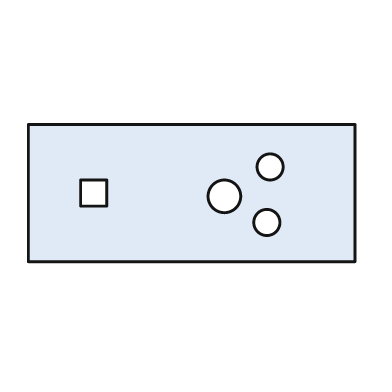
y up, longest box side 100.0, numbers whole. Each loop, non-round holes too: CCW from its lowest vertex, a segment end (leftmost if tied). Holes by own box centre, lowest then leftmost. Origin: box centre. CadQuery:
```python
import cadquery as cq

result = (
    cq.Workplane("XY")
    .moveTo(-50.0, -21.0)
    .lineTo(50.0, -21.0)
    .lineTo(50.0, 21.0)
    .lineTo(-50.0, 21.0)
    .close()
    .moveTo(23.0, -9.0)
    .circle(4.0)
    .moveTo(10.0, -1.0)
    .circle(5.0)
    .moveTo(-34.0, -4.0)
    .lineTo(-26.0, -4.0)
    .lineTo(-26.0, 4.0)
    .lineTo(-34.0, 4.0)
    .close()
    .moveTo(24.0, 8.0)
    .circle(4.0)
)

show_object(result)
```